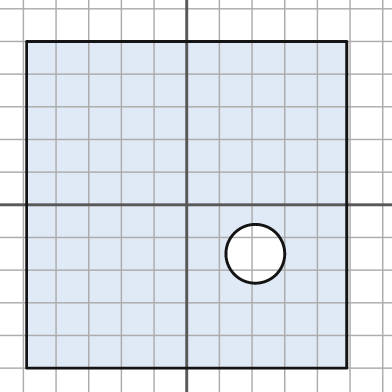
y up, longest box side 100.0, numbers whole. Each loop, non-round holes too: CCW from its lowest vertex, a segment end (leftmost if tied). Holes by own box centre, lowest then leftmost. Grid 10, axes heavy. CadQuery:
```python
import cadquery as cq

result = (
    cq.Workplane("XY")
    .moveTo(-49.0, -50.0)
    .lineTo(49.0, -50.0)
    .lineTo(49.0, 50.0)
    .lineTo(-49.0, 50.0)
    .close()
    .moveTo(21.0, -15.0)
    .circle(9.0)
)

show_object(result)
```